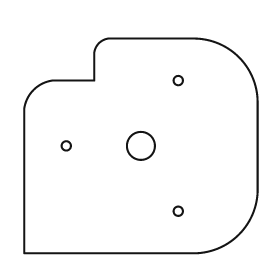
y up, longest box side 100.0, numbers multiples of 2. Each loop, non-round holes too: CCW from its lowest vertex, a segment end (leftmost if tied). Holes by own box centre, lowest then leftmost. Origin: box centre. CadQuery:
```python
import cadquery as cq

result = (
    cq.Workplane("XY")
    .moveTo(-50.0, -46.0)
    .lineTo(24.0, -46.0)
    .threePointArc((42.0, -38.0), (50.0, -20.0))
    .lineTo(50.0, 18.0)
    .threePointArc((42.0, 38.0), (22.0, 46.0))
    .lineTo(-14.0, 46.0)
    .threePointArc((-18.0, 44.0), (-20.0, 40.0))
    .lineTo(-20.0, 28.0)
    .lineTo(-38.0, 28.0)
    .threePointArc((-46.0, 24.0), (-50.0, 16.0))
    .close()
    .moveTo(16.0, -28.0)
    .circle(2.0)
    .moveTo(-32.0, 0.0)
    .circle(2.0)
    .moveTo(0.0, 0.0)
    .circle(6.0)
    .moveTo(16.0, 28.0)
    .circle(2.0)
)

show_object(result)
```